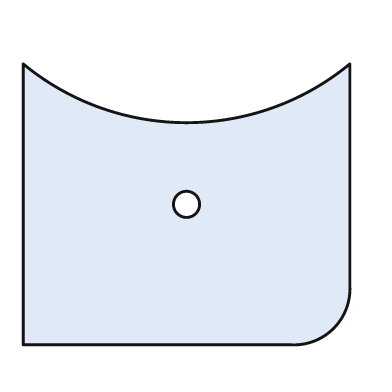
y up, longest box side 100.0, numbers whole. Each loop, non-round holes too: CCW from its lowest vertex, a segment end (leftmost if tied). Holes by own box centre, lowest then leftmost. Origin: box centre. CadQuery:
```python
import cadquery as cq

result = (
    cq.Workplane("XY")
    .moveTo(-50.0, -43.0)
    .lineTo(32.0, -43.0)
    .threePointArc((45.0, -38.0), (50.0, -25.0))
    .lineTo(50.0, 43.0)
    .threePointArc((0.0, 25.0), (-50.0, 43.0))
    .close()
    .moveTo(0.0, 0.0)
    .circle(4.0)
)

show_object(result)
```